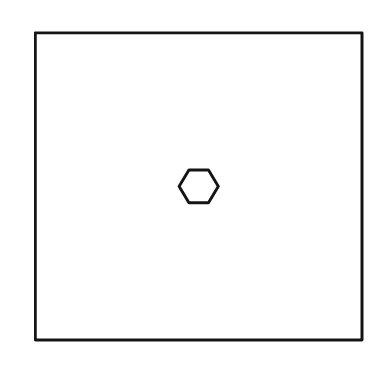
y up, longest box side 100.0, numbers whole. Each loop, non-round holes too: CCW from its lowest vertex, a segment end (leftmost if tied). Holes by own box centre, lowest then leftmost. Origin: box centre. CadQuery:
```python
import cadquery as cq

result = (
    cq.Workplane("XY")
    .moveTo(-50.0, -47.0)
    .lineTo(50.0, -47.0)
    .lineTo(50.0, 47.0)
    .lineTo(-50.0, 47.0)
    .close()
    .moveTo(-3.0, -5.0)
    .lineTo(3.0, -5.0)
    .lineTo(6.0, 0.0)
    .lineTo(3.0, 5.0)
    .lineTo(-3.0, 5.0)
    .lineTo(-6.0, 0.0)
    .close()
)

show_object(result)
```